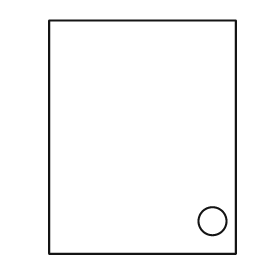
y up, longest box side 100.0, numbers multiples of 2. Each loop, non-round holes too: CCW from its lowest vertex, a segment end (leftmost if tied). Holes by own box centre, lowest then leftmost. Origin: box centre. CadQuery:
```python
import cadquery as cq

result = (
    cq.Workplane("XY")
    .moveTo(-40.0, -50.0)
    .lineTo(40.0, -50.0)
    .lineTo(40.0, 50.0)
    .lineTo(-40.0, 50.0)
    .close()
    .moveTo(30.0, -36.0)
    .circle(6.0)
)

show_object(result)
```